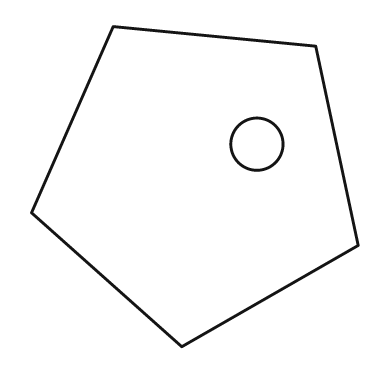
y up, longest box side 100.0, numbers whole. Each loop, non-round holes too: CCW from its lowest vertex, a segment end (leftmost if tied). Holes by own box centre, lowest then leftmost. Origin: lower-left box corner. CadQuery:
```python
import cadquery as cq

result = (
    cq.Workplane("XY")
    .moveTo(46.0, 0.0)
    .lineTo(100.0, 31.0)
    .lineTo(87.0, 92.0)
    .lineTo(25.0, 98.0)
    .lineTo(0.0, 41.0)
    .close()
    .moveTo(69.0, 62.0)
    .circle(8.0)
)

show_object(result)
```